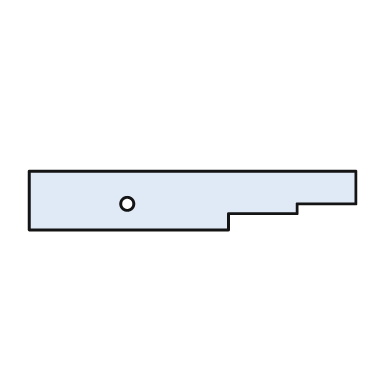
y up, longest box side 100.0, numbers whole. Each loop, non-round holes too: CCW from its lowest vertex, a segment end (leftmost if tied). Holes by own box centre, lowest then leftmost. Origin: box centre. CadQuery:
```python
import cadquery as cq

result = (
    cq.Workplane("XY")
    .moveTo(-50.0, -9.0)
    .lineTo(11.0, -9.0)
    .lineTo(11.0, -4.0)
    .lineTo(32.0, -4.0)
    .lineTo(32.0, -1.0)
    .lineTo(50.0, -1.0)
    .lineTo(50.0, 9.0)
    .lineTo(-50.0, 9.0)
    .close()
    .moveTo(-20.0, -1.0)
    .circle(2.0)
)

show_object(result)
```